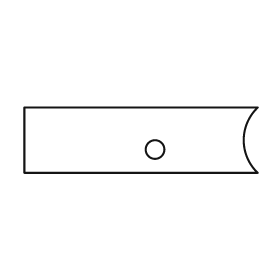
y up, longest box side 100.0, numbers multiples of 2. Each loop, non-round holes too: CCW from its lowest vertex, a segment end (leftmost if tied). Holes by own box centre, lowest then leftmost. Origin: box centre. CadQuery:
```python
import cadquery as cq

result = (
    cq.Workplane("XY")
    .moveTo(-50.0, -14.0)
    .lineTo(50.0, -14.0)
    .threePointArc((44.0, 0.0), (50.0, 14.0))
    .lineTo(-50.0, 14.0)
    .close()
    .moveTo(6.0, -4.0)
    .circle(4.0)
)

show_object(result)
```